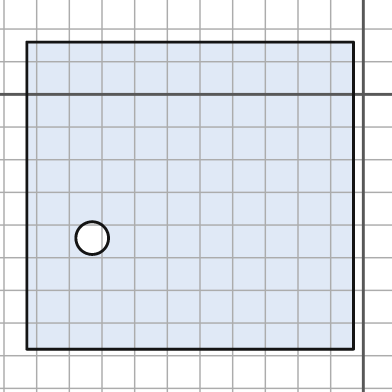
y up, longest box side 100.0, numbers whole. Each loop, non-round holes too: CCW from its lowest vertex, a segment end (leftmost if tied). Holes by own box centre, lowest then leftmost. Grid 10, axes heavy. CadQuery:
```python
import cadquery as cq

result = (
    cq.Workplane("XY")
    .moveTo(-103.0, -78.0)
    .lineTo(-3.0, -78.0)
    .lineTo(-3.0, 16.0)
    .lineTo(-103.0, 16.0)
    .close()
    .moveTo(-83.0, -44.0)
    .circle(5.0)
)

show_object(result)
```